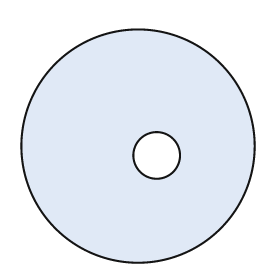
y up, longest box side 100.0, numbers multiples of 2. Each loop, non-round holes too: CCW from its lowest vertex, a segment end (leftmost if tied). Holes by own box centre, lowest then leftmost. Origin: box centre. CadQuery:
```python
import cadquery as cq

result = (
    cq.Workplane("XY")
    .moveTo(0.0, 0.0)
    .circle(50.0)
    .moveTo(8.0, -4.0)
    .circle(10.0)
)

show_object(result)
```